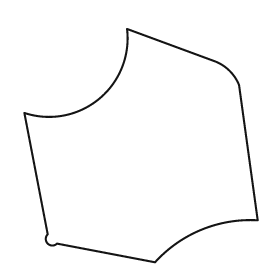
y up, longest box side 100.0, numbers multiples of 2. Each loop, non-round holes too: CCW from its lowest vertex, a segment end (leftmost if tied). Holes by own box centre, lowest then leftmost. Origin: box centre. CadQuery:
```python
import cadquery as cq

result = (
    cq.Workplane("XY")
    .moveTo(6.0, -50.0)
    .threePointArc((26.0, -36.0), (50.0, -32.0))
    .lineTo(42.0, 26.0)
    .threePointArc((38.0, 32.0), (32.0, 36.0))
    .lineTo(-6.0, 50.0)
    .threePointArc((-18.0, 20.0), (-50.0, 14.0))
    .lineTo(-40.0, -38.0)
    .threePointArc((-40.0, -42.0), (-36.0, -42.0))
    .close()
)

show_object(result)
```